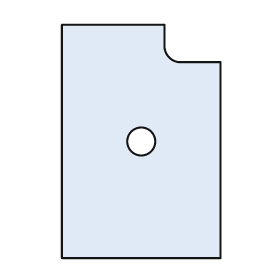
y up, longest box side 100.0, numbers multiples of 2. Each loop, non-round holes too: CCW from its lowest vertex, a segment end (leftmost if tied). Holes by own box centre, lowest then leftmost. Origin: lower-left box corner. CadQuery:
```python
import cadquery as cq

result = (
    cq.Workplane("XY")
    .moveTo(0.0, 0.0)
    .lineTo(68.0, 0.0)
    .lineTo(68.0, 84.0)
    .lineTo(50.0, 84.0)
    .threePointArc((46.0, 86.0), (44.0, 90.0))
    .lineTo(44.0, 100.0)
    .lineTo(0.0, 100.0)
    .close()
    .moveTo(34.0, 50.0)
    .circle(6.0)
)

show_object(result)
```